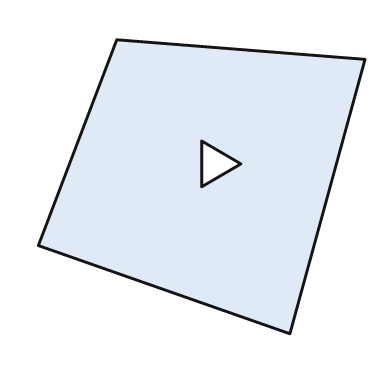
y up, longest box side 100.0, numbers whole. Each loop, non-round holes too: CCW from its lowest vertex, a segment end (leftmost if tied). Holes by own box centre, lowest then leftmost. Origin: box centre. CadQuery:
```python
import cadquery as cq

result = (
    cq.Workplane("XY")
    .moveTo(27.0, -45.0)
    .lineTo(50.0, 39.0)
    .lineTo(-26.0, 45.0)
    .lineTo(-50.0, -18.0)
    .close()
    .moveTo(0.0, 0.0)
    .lineTo(12.0, 7.0)
    .lineTo(0.0, 14.0)
    .close()
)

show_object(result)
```